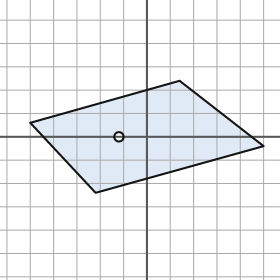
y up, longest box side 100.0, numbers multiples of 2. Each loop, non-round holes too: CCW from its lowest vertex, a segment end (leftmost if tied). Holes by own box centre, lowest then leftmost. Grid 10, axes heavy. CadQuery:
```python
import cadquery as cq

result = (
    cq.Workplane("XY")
    .moveTo(-22.0, -24.0)
    .lineTo(50.0, -4.0)
    .lineTo(14.0, 24.0)
    .lineTo(-50.0, 6.0)
    .close()
    .moveTo(-12.0, 0.0)
    .circle(2.0)
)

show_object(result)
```